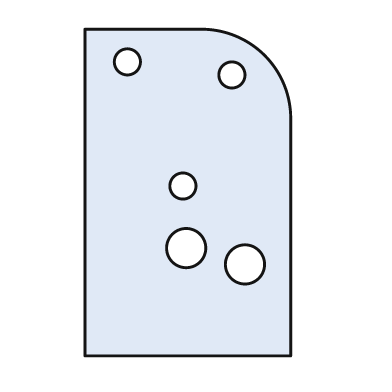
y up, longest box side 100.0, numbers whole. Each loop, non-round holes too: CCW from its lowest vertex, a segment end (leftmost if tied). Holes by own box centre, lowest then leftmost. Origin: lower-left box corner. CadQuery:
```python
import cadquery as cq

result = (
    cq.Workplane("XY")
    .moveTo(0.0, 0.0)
    .lineTo(63.0, 0.0)
    .lineTo(63.0, 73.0)
    .threePointArc((55.0, 92.0), (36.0, 100.0))
    .lineTo(0.0, 100.0)
    .close()
    .moveTo(49.0, 28.0)
    .circle(6.0)
    .moveTo(31.0, 33.0)
    .circle(6.0)
    .moveTo(30.0, 52.0)
    .circle(4.0)
    .moveTo(45.0, 86.0)
    .circle(4.0)
    .moveTo(13.0, 90.0)
    .circle(4.0)
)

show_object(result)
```